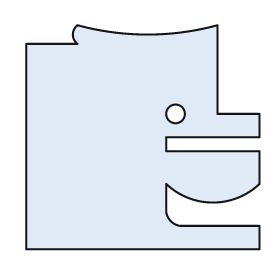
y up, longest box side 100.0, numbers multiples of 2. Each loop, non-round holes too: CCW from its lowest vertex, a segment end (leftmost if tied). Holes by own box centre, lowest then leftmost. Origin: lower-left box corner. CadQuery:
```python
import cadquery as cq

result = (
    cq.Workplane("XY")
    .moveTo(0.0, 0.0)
    .lineTo(100.0, 0.0)
    .lineTo(100.0, 10.0)
    .lineTo(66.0, 10.0)
    .threePointArc((62.0, 12.0), (60.0, 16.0))
    .lineTo(60.0, 28.0)
    .threePointArc((80.0, 20.0), (100.0, 28.0))
    .lineTo(100.0, 42.0)
    .lineTo(60.0, 42.0)
    .lineTo(60.0, 48.0)
    .lineTo(100.0, 48.0)
    .lineTo(100.0, 58.0)
    .lineTo(82.0, 58.0)
    .lineTo(82.0, 96.0)
    .threePointArc((52.0, 92.0), (22.0, 96.0))
    .threePointArc((20.0, 92.0), (22.0, 88.0))
    .lineTo(0.0, 88.0)
    .close()
    .moveTo(64.0, 58.0)
    .circle(4.0)
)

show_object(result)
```